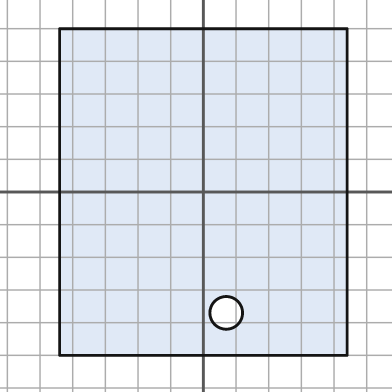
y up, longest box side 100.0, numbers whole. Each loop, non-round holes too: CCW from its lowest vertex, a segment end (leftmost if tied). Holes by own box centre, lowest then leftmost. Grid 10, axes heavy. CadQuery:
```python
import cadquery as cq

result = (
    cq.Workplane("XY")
    .moveTo(-44.0, -50.0)
    .lineTo(44.0, -50.0)
    .lineTo(44.0, 50.0)
    .lineTo(-44.0, 50.0)
    .close()
    .moveTo(7.0, -37.0)
    .circle(5.0)
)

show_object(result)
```